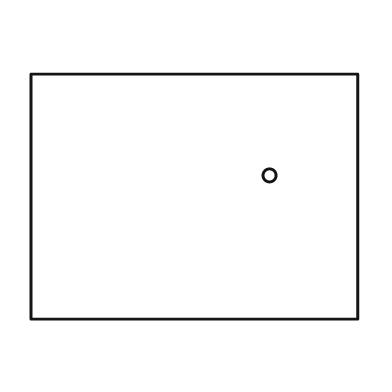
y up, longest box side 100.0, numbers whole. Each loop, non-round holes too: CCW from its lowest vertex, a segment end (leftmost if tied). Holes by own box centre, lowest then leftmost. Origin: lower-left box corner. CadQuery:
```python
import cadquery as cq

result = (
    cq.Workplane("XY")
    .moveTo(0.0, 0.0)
    .lineTo(100.0, 0.0)
    .lineTo(100.0, 75.0)
    .lineTo(0.0, 75.0)
    .close()
    .moveTo(73.0, 44.0)
    .circle(2.0)
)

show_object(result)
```